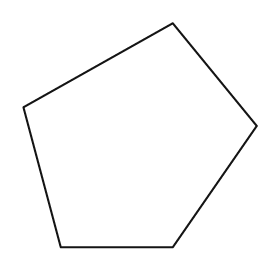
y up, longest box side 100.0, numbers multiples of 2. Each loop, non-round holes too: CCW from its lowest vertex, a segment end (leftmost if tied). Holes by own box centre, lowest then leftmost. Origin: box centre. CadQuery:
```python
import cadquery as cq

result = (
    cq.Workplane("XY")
    .moveTo(-34.0, -48.0)
    .lineTo(14.0, -48.0)
    .lineTo(50.0, 4.0)
    .lineTo(14.0, 48.0)
    .lineTo(-50.0, 12.0)
    .close()
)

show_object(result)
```